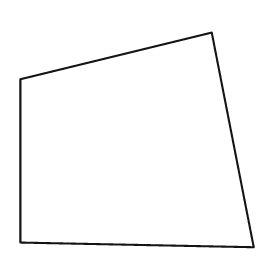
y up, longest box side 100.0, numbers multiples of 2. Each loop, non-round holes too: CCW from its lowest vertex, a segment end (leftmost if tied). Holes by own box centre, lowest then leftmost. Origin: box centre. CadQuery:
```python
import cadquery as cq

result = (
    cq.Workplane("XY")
    .moveTo(50.0, -46.0)
    .lineTo(32.0, 46.0)
    .lineTo(-50.0, 26.0)
    .lineTo(-50.0, -44.0)
    .close()
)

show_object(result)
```